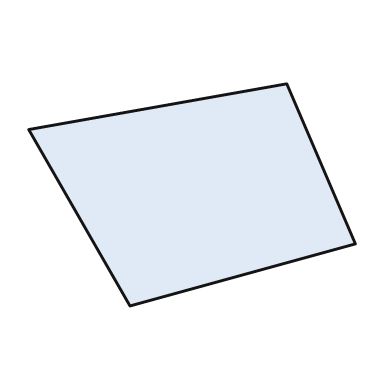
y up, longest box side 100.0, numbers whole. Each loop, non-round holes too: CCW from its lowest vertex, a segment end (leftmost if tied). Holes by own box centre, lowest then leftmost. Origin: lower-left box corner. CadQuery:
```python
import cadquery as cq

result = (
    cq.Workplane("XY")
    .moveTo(31.0, 0.0)
    .lineTo(100.0, 19.0)
    .lineTo(79.0, 68.0)
    .lineTo(0.0, 54.0)
    .close()
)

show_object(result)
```